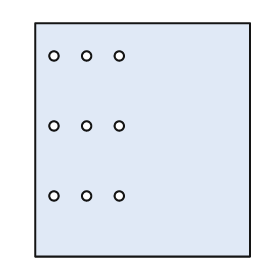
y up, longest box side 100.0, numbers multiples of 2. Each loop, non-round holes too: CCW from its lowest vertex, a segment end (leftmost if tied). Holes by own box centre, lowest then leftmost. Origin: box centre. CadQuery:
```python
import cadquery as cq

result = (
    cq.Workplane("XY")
    .moveTo(-46.0, -50.0)
    .lineTo(46.0, -50.0)
    .lineTo(46.0, 50.0)
    .lineTo(-46.0, 50.0)
    .close()
    .moveTo(-38.0, -24.0)
    .circle(2.0)
    .moveTo(-24.0, -24.0)
    .circle(2.0)
    .moveTo(-10.0, -24.0)
    .circle(2.0)
    .moveTo(-38.0, 6.0)
    .circle(2.0)
    .moveTo(-24.0, 6.0)
    .circle(2.0)
    .moveTo(-10.0, 6.0)
    .circle(2.0)
    .moveTo(-38.0, 36.0)
    .circle(2.0)
    .moveTo(-24.0, 36.0)
    .circle(2.0)
    .moveTo(-10.0, 36.0)
    .circle(2.0)
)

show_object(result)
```